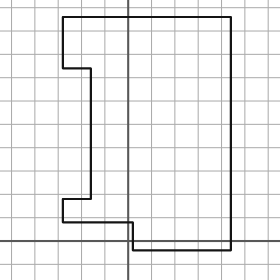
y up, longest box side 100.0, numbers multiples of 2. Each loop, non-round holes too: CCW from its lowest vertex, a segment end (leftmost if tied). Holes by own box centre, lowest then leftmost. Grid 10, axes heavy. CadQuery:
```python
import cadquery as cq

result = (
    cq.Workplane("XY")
    .moveTo(2.0, -4.0)
    .lineTo(44.0, -4.0)
    .lineTo(44.0, 96.0)
    .lineTo(-28.0, 96.0)
    .lineTo(-28.0, 74.0)
    .lineTo(-16.0, 74.0)
    .lineTo(-16.0, 18.0)
    .lineTo(-28.0, 18.0)
    .lineTo(-28.0, 8.0)
    .lineTo(2.0, 8.0)
    .close()
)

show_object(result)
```